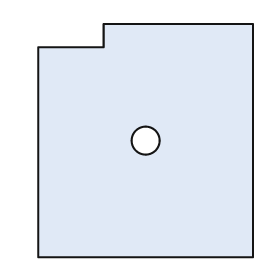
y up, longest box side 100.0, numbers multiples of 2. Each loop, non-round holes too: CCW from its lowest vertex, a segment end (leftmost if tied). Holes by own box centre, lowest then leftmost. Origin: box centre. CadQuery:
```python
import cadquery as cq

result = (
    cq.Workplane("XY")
    .moveTo(-46.0, -50.0)
    .lineTo(46.0, -50.0)
    .lineTo(46.0, 50.0)
    .lineTo(-18.0, 50.0)
    .lineTo(-18.0, 40.0)
    .lineTo(-46.0, 40.0)
    .close()
    .moveTo(0.0, 0.0)
    .circle(6.0)
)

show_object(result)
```